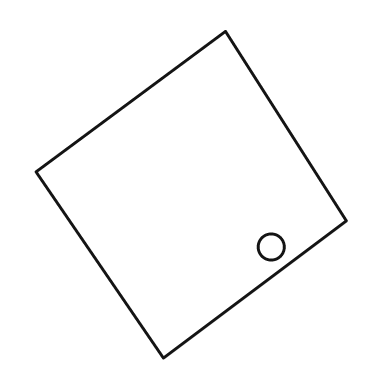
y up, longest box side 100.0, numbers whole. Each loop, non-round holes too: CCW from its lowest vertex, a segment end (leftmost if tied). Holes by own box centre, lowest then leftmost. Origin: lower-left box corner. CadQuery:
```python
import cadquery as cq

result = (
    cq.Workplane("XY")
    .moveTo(39.0, 0.0)
    .lineTo(95.0, 42.0)
    .lineTo(58.0, 100.0)
    .lineTo(0.0, 57.0)
    .close()
    .moveTo(72.0, 34.0)
    .circle(4.0)
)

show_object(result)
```